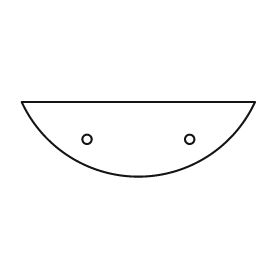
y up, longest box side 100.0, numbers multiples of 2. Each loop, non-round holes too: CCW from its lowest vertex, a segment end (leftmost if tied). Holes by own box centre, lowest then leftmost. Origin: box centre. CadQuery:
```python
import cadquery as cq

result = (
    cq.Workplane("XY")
    .moveTo(-50.0, 16.0)
    .threePointArc((0.0, -16.0), (50.0, 16.0))
    .close()
    .moveTo(-22.0, 0.0)
    .circle(2.0)
    .moveTo(22.0, 0.0)
    .circle(2.0)
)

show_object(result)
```